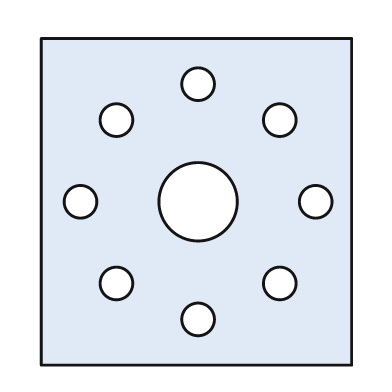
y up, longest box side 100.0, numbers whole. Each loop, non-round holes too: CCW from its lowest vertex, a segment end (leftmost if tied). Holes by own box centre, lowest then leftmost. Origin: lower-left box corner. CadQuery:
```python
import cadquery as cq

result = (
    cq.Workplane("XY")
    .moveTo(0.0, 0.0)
    .lineTo(95.0, 0.0)
    .lineTo(95.0, 100.0)
    .lineTo(0.0, 100.0)
    .close()
    .moveTo(48.0, 14.0)
    .circle(5.0)
    .moveTo(23.0, 25.0)
    .circle(5.0)
    .moveTo(73.0, 25.0)
    .circle(5.0)
    .moveTo(12.0, 50.0)
    .circle(5.0)
    .moveTo(48.0, 50.0)
    .circle(12.0)
    .moveTo(84.0, 50.0)
    .circle(5.0)
    .moveTo(23.0, 75.0)
    .circle(5.0)
    .moveTo(73.0, 75.0)
    .circle(5.0)
    .moveTo(48.0, 86.0)
    .circle(5.0)
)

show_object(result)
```